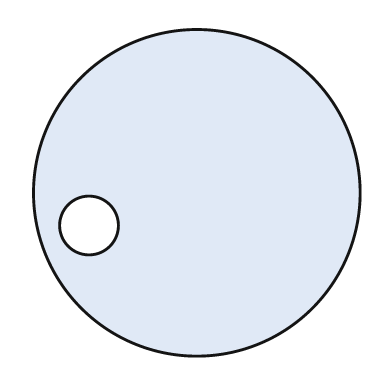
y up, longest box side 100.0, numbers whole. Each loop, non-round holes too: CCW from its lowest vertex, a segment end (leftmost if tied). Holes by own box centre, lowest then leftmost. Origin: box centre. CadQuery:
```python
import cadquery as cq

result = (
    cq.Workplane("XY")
    .moveTo(0.0, 0.0)
    .circle(50.0)
    .moveTo(-33.0, -10.0)
    .circle(9.0)
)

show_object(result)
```